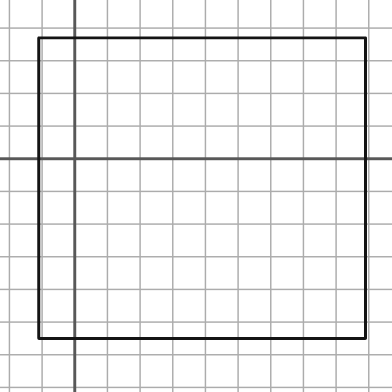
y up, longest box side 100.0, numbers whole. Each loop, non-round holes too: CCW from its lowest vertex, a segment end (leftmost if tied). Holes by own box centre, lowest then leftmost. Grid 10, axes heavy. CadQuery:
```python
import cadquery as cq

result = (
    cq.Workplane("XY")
    .moveTo(-11.0, -55.0)
    .lineTo(89.0, -55.0)
    .lineTo(89.0, 37.0)
    .lineTo(-11.0, 37.0)
    .close()
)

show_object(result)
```